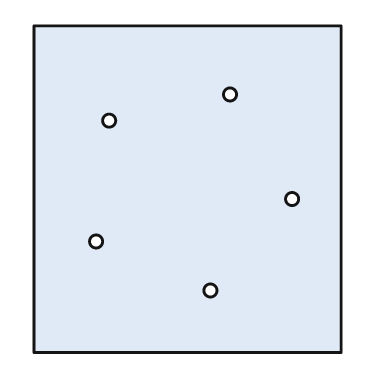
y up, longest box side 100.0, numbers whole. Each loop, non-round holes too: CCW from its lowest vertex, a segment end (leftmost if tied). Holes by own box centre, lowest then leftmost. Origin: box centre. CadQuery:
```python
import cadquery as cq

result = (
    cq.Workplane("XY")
    .moveTo(-47.0, -50.0)
    .lineTo(47.0, -50.0)
    .lineTo(47.0, 50.0)
    .lineTo(-47.0, 50.0)
    .close()
    .moveTo(7.0, -31.0)
    .circle(2.0)
    .moveTo(-28.0, -16.0)
    .circle(2.0)
    .moveTo(32.0, -3.0)
    .circle(2.0)
    .moveTo(-24.0, 21.0)
    .circle(2.0)
    .moveTo(13.0, 29.0)
    .circle(2.0)
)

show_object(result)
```